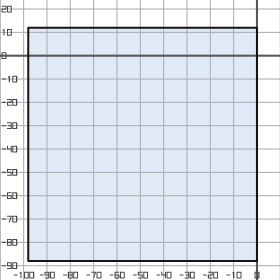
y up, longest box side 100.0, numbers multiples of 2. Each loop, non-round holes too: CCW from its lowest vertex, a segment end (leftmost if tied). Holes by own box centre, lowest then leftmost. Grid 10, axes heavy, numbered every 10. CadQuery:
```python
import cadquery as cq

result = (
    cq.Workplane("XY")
    .moveTo(-98.0, -88.0)
    .lineTo(0.0, -88.0)
    .lineTo(0.0, 12.0)
    .lineTo(-98.0, 12.0)
    .close()
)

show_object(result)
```